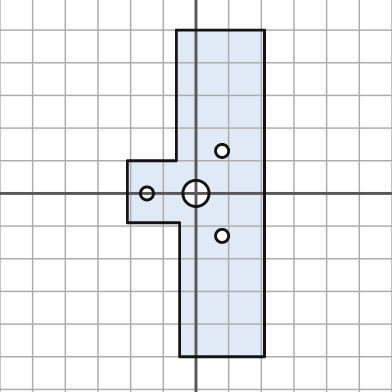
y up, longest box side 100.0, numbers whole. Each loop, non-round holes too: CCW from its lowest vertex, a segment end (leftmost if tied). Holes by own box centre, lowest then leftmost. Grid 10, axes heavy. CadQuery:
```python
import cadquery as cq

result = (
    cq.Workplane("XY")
    .moveTo(-5.0, -50.0)
    .lineTo(21.0, -50.0)
    .lineTo(21.0, 50.0)
    .lineTo(-6.0, 50.0)
    .lineTo(-6.0, 10.0)
    .lineTo(-21.0, 10.0)
    .lineTo(-21.0, -9.0)
    .lineTo(-5.0, -9.0)
    .close()
    .moveTo(8.0, -13.0)
    .circle(2.0)
    .moveTo(-15.0, 0.0)
    .circle(2.0)
    .moveTo(0.0, 0.0)
    .circle(4.0)
    .moveTo(8.0, 13.0)
    .circle(2.0)
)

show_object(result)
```